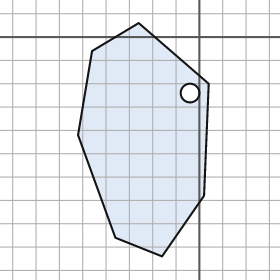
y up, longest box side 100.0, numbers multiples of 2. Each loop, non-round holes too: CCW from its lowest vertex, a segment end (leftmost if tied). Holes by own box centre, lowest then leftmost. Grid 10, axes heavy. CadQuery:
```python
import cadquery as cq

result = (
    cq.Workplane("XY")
    .moveTo(-16.0, -94.0)
    .lineTo(2.0, -68.0)
    .lineTo(4.0, -20.0)
    .lineTo(-26.0, 6.0)
    .lineTo(-46.0, -6.0)
    .lineTo(-52.0, -42.0)
    .lineTo(-36.0, -86.0)
    .close()
    .moveTo(-4.0, -24.0)
    .circle(4.0)
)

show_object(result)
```